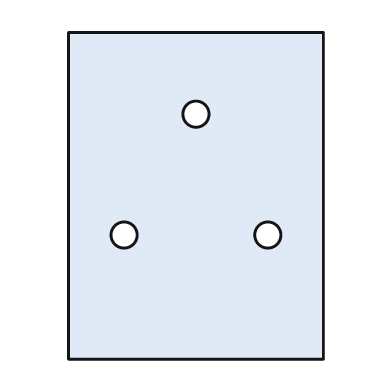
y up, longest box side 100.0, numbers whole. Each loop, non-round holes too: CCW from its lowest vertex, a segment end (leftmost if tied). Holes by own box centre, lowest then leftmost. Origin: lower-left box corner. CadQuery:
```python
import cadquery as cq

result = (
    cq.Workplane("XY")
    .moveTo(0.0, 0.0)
    .lineTo(78.0, 0.0)
    .lineTo(78.0, 100.0)
    .lineTo(0.0, 100.0)
    .close()
    .moveTo(17.0, 38.0)
    .circle(4.0)
    .moveTo(61.0, 38.0)
    .circle(4.0)
    .moveTo(39.0, 75.0)
    .circle(4.0)
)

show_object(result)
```